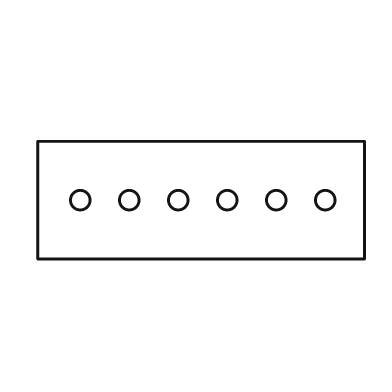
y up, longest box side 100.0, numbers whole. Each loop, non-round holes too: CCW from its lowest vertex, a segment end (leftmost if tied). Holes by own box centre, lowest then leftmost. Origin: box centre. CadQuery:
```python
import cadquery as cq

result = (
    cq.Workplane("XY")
    .moveTo(-50.0, -18.0)
    .lineTo(50.0, -18.0)
    .lineTo(50.0, 18.0)
    .lineTo(-50.0, 18.0)
    .close()
    .moveTo(-37.0, 0.0)
    .circle(3.0)
    .moveTo(-22.0, 0.0)
    .circle(3.0)
    .moveTo(-7.0, 0.0)
    .circle(3.0)
    .moveTo(8.0, 0.0)
    .circle(3.0)
    .moveTo(23.0, 0.0)
    .circle(3.0)
    .moveTo(38.0, 0.0)
    .circle(3.0)
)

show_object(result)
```